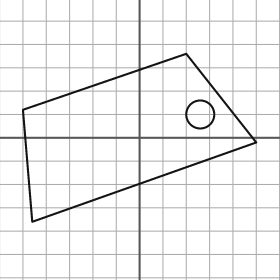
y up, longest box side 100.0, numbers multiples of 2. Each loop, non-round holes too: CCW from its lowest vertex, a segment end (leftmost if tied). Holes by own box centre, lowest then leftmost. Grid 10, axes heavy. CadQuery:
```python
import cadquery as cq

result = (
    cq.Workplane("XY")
    .moveTo(-46.0, -36.0)
    .lineTo(50.0, -2.0)
    .lineTo(20.0, 36.0)
    .lineTo(-50.0, 12.0)
    .close()
    .moveTo(26.0, 10.0)
    .circle(6.0)
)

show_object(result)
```